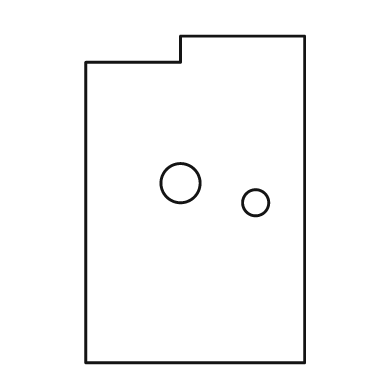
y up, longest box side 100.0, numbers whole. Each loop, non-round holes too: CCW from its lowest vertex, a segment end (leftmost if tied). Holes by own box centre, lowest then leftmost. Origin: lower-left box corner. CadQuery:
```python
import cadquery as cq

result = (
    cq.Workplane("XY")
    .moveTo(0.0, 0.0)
    .lineTo(67.0, 0.0)
    .lineTo(67.0, 100.0)
    .lineTo(29.0, 100.0)
    .lineTo(29.0, 92.0)
    .lineTo(0.0, 92.0)
    .close()
    .moveTo(52.0, 49.0)
    .circle(4.0)
    .moveTo(29.0, 55.0)
    .circle(6.0)
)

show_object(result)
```